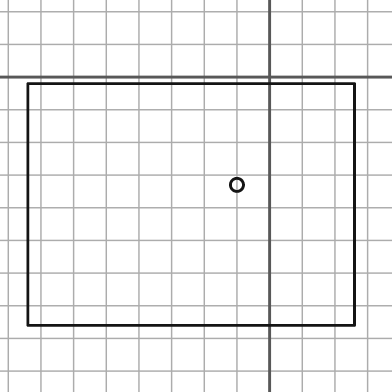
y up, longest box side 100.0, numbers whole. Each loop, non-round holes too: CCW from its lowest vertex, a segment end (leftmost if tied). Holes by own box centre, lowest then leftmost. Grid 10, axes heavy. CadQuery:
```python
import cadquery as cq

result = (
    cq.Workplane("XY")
    .moveTo(-74.0, -76.0)
    .lineTo(26.0, -76.0)
    .lineTo(26.0, -2.0)
    .lineTo(-74.0, -2.0)
    .close()
    .moveTo(-10.0, -33.0)
    .circle(2.0)
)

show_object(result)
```